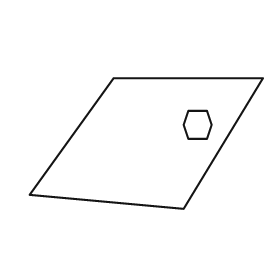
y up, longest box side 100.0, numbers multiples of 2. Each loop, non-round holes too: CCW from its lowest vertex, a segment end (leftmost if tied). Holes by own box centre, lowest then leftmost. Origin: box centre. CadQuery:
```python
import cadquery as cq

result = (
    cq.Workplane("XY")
    .moveTo(16.0, -28.0)
    .lineTo(50.0, 28.0)
    .lineTo(-14.0, 28.0)
    .lineTo(-50.0, -22.0)
    .close()
    .moveTo(18.0, 2.0)
    .lineTo(26.0, 2.0)
    .lineTo(28.0, 8.0)
    .lineTo(26.0, 14.0)
    .lineTo(18.0, 14.0)
    .lineTo(16.0, 8.0)
    .close()
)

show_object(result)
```